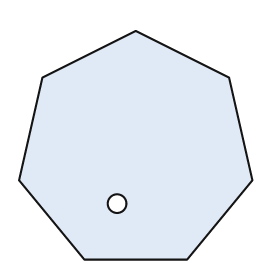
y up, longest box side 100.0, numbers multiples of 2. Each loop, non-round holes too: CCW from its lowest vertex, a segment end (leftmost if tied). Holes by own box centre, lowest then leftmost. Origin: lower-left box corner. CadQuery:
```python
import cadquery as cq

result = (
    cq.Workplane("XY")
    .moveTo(28.0, 0.0)
    .lineTo(72.0, 0.0)
    .lineTo(100.0, 34.0)
    .lineTo(90.0, 78.0)
    .lineTo(50.0, 98.0)
    .lineTo(10.0, 78.0)
    .lineTo(0.0, 34.0)
    .close()
    .moveTo(42.0, 24.0)
    .circle(4.0)
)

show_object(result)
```